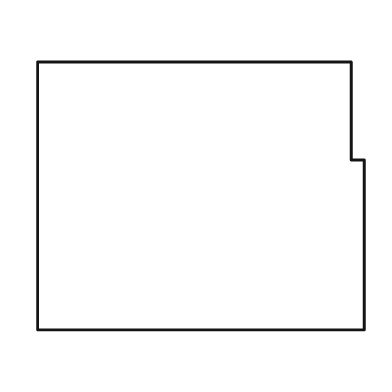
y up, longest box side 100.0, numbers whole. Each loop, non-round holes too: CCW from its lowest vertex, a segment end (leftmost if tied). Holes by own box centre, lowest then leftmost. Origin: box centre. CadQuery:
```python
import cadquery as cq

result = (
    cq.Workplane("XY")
    .moveTo(-50.0, -41.0)
    .lineTo(50.0, -41.0)
    .lineTo(50.0, 11.0)
    .lineTo(46.0, 11.0)
    .lineTo(46.0, 41.0)
    .lineTo(-50.0, 41.0)
    .close()
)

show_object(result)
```